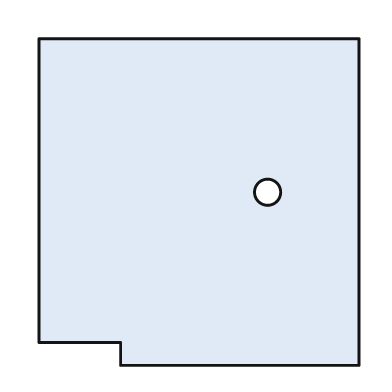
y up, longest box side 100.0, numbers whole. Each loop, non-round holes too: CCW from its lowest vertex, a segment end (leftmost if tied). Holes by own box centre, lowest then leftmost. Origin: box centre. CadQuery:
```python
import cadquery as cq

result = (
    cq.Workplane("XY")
    .moveTo(-24.0, -50.0)
    .lineTo(49.0, -50.0)
    .lineTo(49.0, 50.0)
    .lineTo(-49.0, 50.0)
    .lineTo(-49.0, -43.0)
    .lineTo(-24.0, -43.0)
    .close()
    .moveTo(21.0, 3.0)
    .circle(4.0)
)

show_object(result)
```